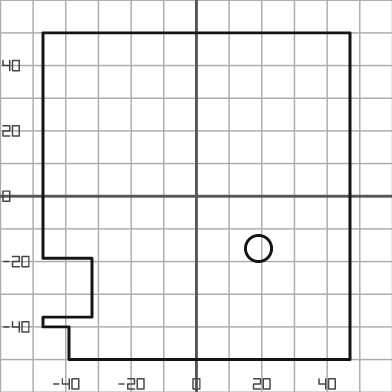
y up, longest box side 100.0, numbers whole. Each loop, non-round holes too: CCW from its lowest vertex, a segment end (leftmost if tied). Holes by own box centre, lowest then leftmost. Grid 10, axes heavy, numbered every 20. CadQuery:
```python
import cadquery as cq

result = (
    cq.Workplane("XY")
    .moveTo(-39.0, -50.0)
    .lineTo(47.0, -50.0)
    .lineTo(47.0, 50.0)
    .lineTo(-47.0, 50.0)
    .lineTo(-47.0, -19.0)
    .lineTo(-32.0, -19.0)
    .lineTo(-32.0, -37.0)
    .lineTo(-47.0, -37.0)
    .lineTo(-47.0, -40.0)
    .lineTo(-39.0, -40.0)
    .close()
    .moveTo(19.0, -16.0)
    .circle(4.0)
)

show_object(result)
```